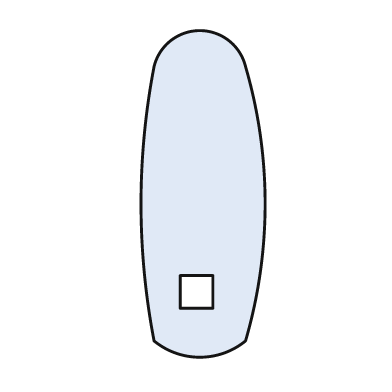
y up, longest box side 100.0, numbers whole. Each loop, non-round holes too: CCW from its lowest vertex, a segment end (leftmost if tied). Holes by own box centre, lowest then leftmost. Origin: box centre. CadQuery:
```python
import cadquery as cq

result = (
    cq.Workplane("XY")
    .moveTo(-15.0, -45.0)
    .threePointArc((-1.0, -50.0), (13.0, -45.0))
    .threePointArc((19.0, -3.0), (13.0, 39.0))
    .threePointArc((-1.0, 50.0), (-15.0, 39.0))
    .threePointArc((-19.0, -3.0), (-15.0, -45.0))
    .close()
    .moveTo(-7.0, -35.0)
    .lineTo(3.0, -35.0)
    .lineTo(3.0, -25.0)
    .lineTo(-7.0, -25.0)
    .close()
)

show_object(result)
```